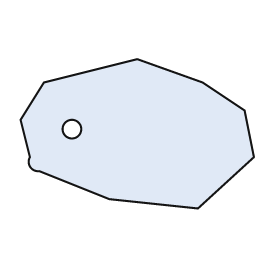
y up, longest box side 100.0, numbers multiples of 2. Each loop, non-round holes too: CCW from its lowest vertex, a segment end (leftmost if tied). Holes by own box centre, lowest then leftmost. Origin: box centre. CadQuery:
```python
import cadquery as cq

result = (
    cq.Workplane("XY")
    .moveTo(26.0, -32.0)
    .lineTo(50.0, -10.0)
    .lineTo(46.0, 10.0)
    .lineTo(28.0, 22.0)
    .lineTo(0.0, 32.0)
    .lineTo(-40.0, 22.0)
    .lineTo(-50.0, 6.0)
    .lineTo(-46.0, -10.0)
    .threePointArc((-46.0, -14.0), (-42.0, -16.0))
    .lineTo(-12.0, -28.0)
    .close()
    .moveTo(-28.0, 2.0)
    .circle(4.0)
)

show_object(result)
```